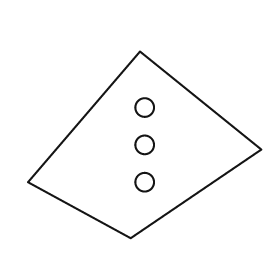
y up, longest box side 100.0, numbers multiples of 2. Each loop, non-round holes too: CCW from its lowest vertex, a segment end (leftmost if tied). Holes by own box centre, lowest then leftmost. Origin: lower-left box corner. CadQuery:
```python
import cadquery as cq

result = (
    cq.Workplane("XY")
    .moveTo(44.0, 0.0)
    .lineTo(100.0, 38.0)
    .lineTo(48.0, 80.0)
    .lineTo(0.0, 24.0)
    .close()
    .moveTo(50.0, 24.0)
    .circle(4.0)
    .moveTo(50.0, 40.0)
    .circle(4.0)
    .moveTo(50.0, 56.0)
    .circle(4.0)
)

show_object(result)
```